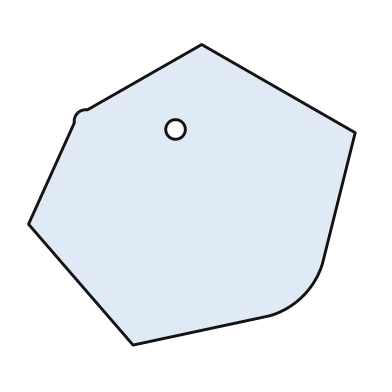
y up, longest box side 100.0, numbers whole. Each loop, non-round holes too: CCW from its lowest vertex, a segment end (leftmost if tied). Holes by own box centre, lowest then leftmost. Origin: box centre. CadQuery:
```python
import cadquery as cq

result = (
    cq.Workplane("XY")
    .moveTo(-18.0, -46.0)
    .lineTo(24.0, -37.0)
    .threePointArc((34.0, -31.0), (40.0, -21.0))
    .lineTo(50.0, 19.0)
    .lineTo(3.0, 46.0)
    .lineTo(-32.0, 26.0)
    .threePointArc((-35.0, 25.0), (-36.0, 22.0))
    .lineTo(-50.0, -9.0)
    .close()
    .moveTo(-5.0, 20.0)
    .circle(3.0)
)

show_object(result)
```